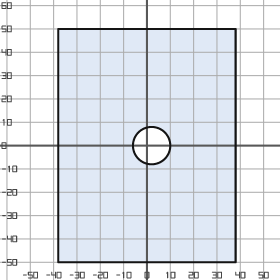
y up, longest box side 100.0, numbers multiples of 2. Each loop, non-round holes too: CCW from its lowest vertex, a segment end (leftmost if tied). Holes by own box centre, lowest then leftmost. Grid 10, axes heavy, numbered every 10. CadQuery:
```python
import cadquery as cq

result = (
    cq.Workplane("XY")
    .moveTo(-38.0, -50.0)
    .lineTo(38.0, -50.0)
    .lineTo(38.0, 50.0)
    .lineTo(-38.0, 50.0)
    .close()
    .moveTo(2.0, 0.0)
    .circle(8.0)
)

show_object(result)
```